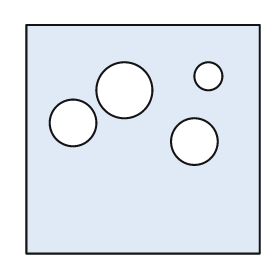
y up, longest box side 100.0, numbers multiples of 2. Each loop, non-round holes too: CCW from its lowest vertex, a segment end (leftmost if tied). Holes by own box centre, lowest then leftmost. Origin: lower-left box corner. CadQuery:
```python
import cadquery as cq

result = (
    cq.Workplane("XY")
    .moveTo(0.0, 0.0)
    .lineTo(100.0, 0.0)
    .lineTo(100.0, 98.0)
    .lineTo(0.0, 98.0)
    .close()
    .moveTo(72.0, 48.0)
    .circle(10.0)
    .moveTo(20.0, 56.0)
    .circle(10.0)
    .moveTo(42.0, 70.0)
    .circle(12.0)
    .moveTo(78.0, 76.0)
    .circle(6.0)
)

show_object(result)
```